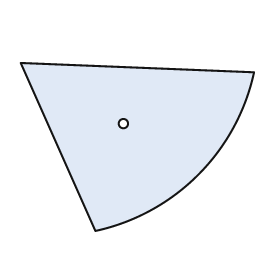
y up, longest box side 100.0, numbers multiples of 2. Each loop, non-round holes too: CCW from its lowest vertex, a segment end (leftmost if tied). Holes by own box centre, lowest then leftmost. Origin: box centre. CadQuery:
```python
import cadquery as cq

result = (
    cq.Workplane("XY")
    .moveTo(-18.0, -36.0)
    .threePointArc((26.0, -12.0), (50.0, 32.0))
    .lineTo(-50.0, 36.0)
    .close()
    .moveTo(-6.0, 10.0)
    .circle(2.0)
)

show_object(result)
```